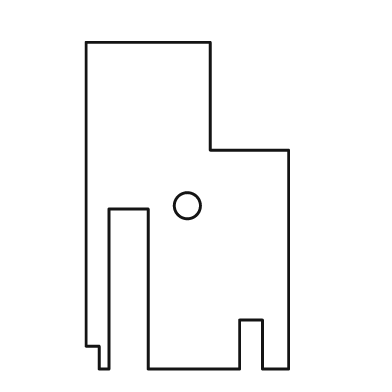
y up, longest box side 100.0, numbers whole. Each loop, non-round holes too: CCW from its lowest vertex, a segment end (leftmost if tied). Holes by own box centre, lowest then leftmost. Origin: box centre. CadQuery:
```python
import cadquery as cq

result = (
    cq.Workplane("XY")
    .moveTo(-27.0, -50.0)
    .lineTo(-24.0, -50.0)
    .lineTo(-24.0, -1.0)
    .lineTo(-12.0, -1.0)
    .lineTo(-12.0, -50.0)
    .lineTo(16.0, -50.0)
    .lineTo(16.0, -35.0)
    .lineTo(23.0, -35.0)
    .lineTo(23.0, -50.0)
    .lineTo(31.0, -50.0)
    .lineTo(31.0, 17.0)
    .lineTo(7.0, 17.0)
    .lineTo(7.0, 50.0)
    .lineTo(-31.0, 50.0)
    .lineTo(-31.0, -43.0)
    .lineTo(-27.0, -43.0)
    .close()
    .moveTo(0.0, 0.0)
    .circle(4.0)
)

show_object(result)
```